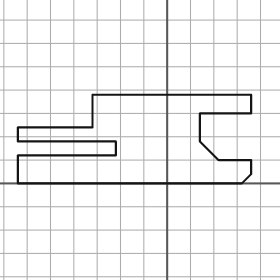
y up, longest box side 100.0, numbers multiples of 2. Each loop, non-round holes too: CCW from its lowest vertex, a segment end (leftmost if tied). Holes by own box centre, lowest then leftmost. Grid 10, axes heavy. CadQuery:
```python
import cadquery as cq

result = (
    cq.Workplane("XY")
    .moveTo(-64.0, 0.0)
    .lineTo(32.0, 0.0)
    .lineTo(36.0, 4.0)
    .lineTo(36.0, 10.0)
    .lineTo(22.0, 10.0)
    .lineTo(14.0, 18.0)
    .lineTo(14.0, 30.0)
    .lineTo(36.0, 30.0)
    .lineTo(36.0, 38.0)
    .lineTo(-32.0, 38.0)
    .lineTo(-32.0, 24.0)
    .lineTo(-64.0, 24.0)
    .lineTo(-64.0, 18.0)
    .lineTo(-22.0, 18.0)
    .lineTo(-22.0, 12.0)
    .lineTo(-64.0, 12.0)
    .close()
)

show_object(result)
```